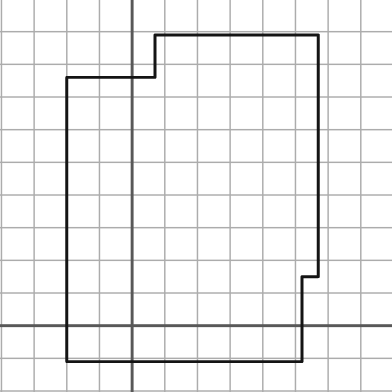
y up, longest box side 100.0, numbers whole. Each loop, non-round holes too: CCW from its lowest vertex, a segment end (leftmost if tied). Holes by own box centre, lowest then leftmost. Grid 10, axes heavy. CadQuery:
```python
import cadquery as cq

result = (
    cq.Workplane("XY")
    .moveTo(-20.0, -11.0)
    .lineTo(52.0, -11.0)
    .lineTo(52.0, 15.0)
    .lineTo(57.0, 15.0)
    .lineTo(57.0, 89.0)
    .lineTo(7.0, 89.0)
    .lineTo(7.0, 76.0)
    .lineTo(-20.0, 76.0)
    .close()
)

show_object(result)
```